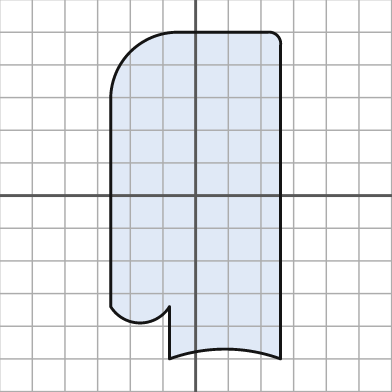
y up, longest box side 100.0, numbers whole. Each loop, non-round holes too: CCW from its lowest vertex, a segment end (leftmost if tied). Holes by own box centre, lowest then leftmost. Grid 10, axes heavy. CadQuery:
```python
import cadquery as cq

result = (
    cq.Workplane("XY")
    .moveTo(-8.0, -50.0)
    .threePointArc((9.0, -47.0), (26.0, -50.0))
    .lineTo(26.0, 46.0)
    .threePointArc((25.0, 49.0), (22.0, 50.0))
    .lineTo(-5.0, 50.0)
    .threePointArc((-20.0, 44.0), (-26.0, 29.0))
    .lineTo(-26.0, -34.0)
    .threePointArc((-17.0, -39.0), (-8.0, -34.0))
    .close()
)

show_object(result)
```